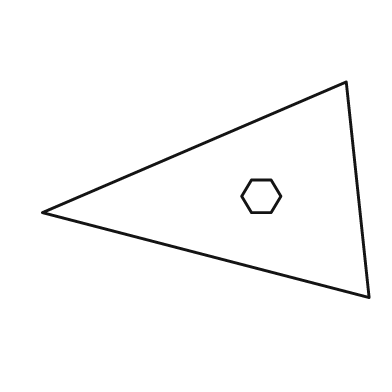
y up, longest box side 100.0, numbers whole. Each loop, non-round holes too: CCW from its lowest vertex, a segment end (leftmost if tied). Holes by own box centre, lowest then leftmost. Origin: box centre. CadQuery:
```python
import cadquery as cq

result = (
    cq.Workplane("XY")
    .moveTo(50.0, -33.0)
    .lineTo(43.0, 33.0)
    .lineTo(-50.0, -7.0)
    .close()
    .moveTo(14.0, -7.0)
    .lineTo(20.0, -7.0)
    .lineTo(23.0, -2.0)
    .lineTo(20.0, 3.0)
    .lineTo(14.0, 3.0)
    .lineTo(11.0, -2.0)
    .close()
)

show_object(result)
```